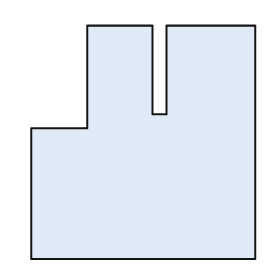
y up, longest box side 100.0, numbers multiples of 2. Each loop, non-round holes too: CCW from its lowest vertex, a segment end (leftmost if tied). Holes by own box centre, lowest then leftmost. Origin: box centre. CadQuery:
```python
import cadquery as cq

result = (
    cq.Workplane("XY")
    .moveTo(-48.0, -50.0)
    .lineTo(48.0, -50.0)
    .lineTo(48.0, 50.0)
    .lineTo(10.0, 50.0)
    .lineTo(10.0, 12.0)
    .lineTo(4.0, 12.0)
    .lineTo(4.0, 50.0)
    .lineTo(-24.0, 50.0)
    .lineTo(-24.0, 6.0)
    .lineTo(-48.0, 6.0)
    .close()
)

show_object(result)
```